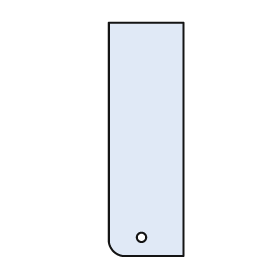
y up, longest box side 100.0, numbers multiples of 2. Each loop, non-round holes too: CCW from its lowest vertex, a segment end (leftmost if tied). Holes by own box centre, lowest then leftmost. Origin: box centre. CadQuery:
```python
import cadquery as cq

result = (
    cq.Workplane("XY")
    .moveTo(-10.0, -50.0)
    .lineTo(16.0, -50.0)
    .lineTo(16.0, 50.0)
    .lineTo(-16.0, 50.0)
    .lineTo(-16.0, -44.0)
    .threePointArc((-14.0, -48.0), (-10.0, -50.0))
    .close()
    .moveTo(-2.0, -42.0)
    .circle(2.0)
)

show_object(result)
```